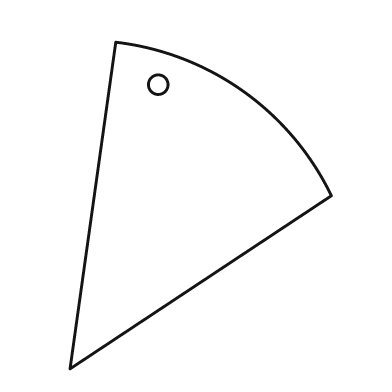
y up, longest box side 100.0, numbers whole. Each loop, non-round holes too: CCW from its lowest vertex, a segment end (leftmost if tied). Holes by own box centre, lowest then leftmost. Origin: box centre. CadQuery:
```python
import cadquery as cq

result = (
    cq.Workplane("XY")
    .moveTo(-40.0, -50.0)
    .lineTo(40.0, 3.0)
    .threePointArc((13.0, 35.0), (-26.0, 50.0))
    .close()
    .moveTo(-13.0, 37.0)
    .circle(3.0)
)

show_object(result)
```